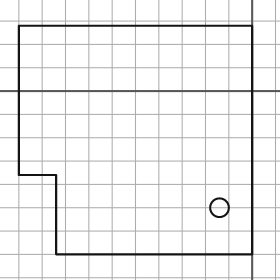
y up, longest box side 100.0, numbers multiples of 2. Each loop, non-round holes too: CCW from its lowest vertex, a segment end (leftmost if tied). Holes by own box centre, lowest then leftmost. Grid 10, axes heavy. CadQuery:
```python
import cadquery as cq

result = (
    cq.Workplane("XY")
    .moveTo(-84.0, -70.0)
    .lineTo(0.0, -70.0)
    .lineTo(0.0, 28.0)
    .lineTo(-100.0, 28.0)
    .lineTo(-100.0, -36.0)
    .lineTo(-84.0, -36.0)
    .close()
    .moveTo(-14.0, -50.0)
    .circle(4.0)
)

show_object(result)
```